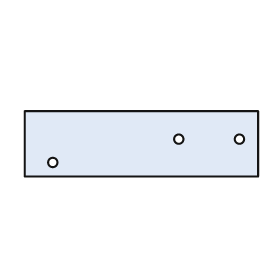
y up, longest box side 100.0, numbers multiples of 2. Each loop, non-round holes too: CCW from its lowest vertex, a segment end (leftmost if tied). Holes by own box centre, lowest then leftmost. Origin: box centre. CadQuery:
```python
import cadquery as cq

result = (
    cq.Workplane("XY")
    .moveTo(-50.0, -14.0)
    .lineTo(50.0, -14.0)
    .lineTo(50.0, 14.0)
    .lineTo(-50.0, 14.0)
    .close()
    .moveTo(-38.0, -8.0)
    .circle(2.0)
    .moveTo(16.0, 2.0)
    .circle(2.0)
    .moveTo(42.0, 2.0)
    .circle(2.0)
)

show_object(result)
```